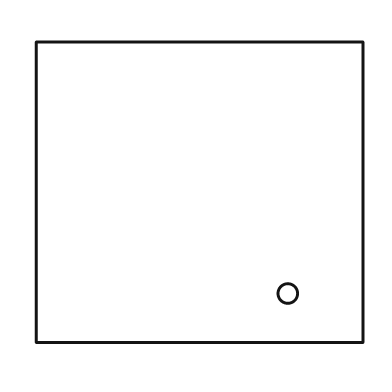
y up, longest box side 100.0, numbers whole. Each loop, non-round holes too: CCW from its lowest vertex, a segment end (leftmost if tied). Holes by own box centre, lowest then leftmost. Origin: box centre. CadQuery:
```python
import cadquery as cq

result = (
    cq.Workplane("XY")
    .moveTo(-50.0, -46.0)
    .lineTo(50.0, -46.0)
    .lineTo(50.0, 46.0)
    .lineTo(-50.0, 46.0)
    .close()
    .moveTo(27.0, -31.0)
    .circle(3.0)
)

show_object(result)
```